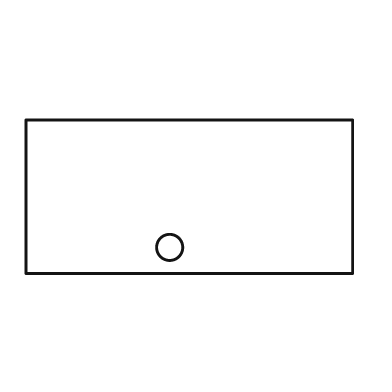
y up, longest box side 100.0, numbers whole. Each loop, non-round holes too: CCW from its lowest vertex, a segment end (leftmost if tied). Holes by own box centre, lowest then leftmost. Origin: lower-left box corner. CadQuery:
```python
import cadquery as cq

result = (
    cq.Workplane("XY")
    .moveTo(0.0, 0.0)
    .lineTo(100.0, 0.0)
    .lineTo(100.0, 47.0)
    .lineTo(0.0, 47.0)
    .close()
    .moveTo(44.0, 8.0)
    .circle(4.0)
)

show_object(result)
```